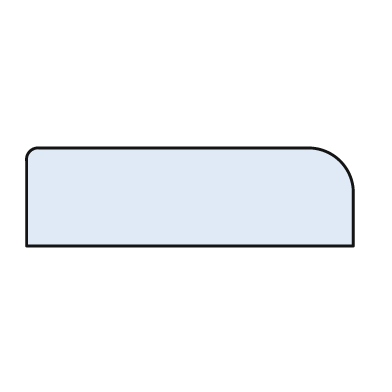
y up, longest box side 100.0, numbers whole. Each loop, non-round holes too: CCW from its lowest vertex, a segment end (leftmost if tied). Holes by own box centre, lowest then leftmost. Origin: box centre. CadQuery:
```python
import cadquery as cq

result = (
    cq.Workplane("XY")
    .moveTo(-50.0, -15.0)
    .lineTo(50.0, -15.0)
    .lineTo(50.0, 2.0)
    .threePointArc((46.0, 11.0), (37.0, 15.0))
    .lineTo(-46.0, 15.0)
    .threePointArc((-49.0, 14.0), (-50.0, 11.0))
    .close()
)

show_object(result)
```